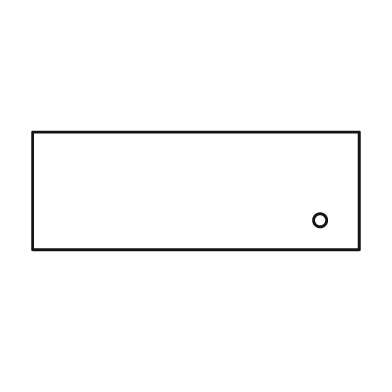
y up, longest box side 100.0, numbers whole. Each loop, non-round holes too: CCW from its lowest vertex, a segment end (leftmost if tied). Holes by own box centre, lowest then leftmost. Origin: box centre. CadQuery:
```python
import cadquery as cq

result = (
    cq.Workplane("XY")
    .moveTo(-50.0, -18.0)
    .lineTo(50.0, -18.0)
    .lineTo(50.0, 18.0)
    .lineTo(-50.0, 18.0)
    .close()
    .moveTo(38.0, -9.0)
    .circle(2.0)
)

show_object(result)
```